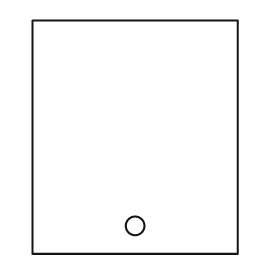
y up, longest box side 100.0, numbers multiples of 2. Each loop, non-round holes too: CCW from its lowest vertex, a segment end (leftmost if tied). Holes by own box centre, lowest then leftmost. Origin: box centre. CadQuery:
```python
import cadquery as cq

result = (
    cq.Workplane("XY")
    .moveTo(-44.0, -50.0)
    .lineTo(44.0, -50.0)
    .lineTo(44.0, 50.0)
    .lineTo(-44.0, 50.0)
    .close()
    .moveTo(0.0, -38.0)
    .circle(4.0)
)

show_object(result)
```